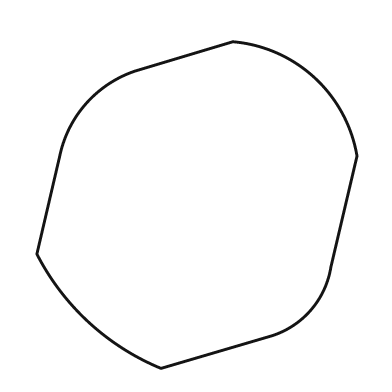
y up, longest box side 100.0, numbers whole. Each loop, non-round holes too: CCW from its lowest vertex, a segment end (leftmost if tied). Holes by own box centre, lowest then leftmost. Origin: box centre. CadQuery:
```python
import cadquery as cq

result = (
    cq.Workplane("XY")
    .moveTo(-11.0, -50.0)
    .lineTo(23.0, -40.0)
    .threePointArc((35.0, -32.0), (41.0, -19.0))
    .lineTo(49.0, 15.0)
    .threePointArc((36.0, 39.0), (11.0, 50.0))
    .lineTo(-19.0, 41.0)
    .threePointArc((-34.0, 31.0), (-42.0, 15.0))
    .lineTo(-49.0, -15.0)
    .threePointArc((-33.0, -36.0), (-11.0, -50.0))
    .close()
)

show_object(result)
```